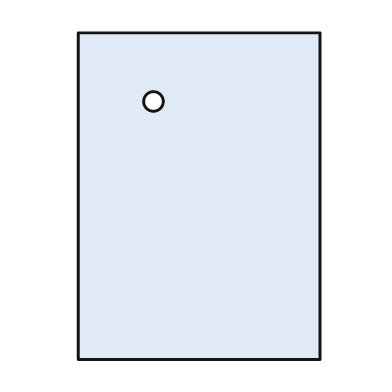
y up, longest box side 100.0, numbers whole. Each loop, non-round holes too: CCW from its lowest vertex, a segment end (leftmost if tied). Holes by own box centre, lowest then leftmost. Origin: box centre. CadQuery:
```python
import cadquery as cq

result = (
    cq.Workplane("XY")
    .moveTo(-37.0, -50.0)
    .lineTo(37.0, -50.0)
    .lineTo(37.0, 50.0)
    .lineTo(-37.0, 50.0)
    .close()
    .moveTo(-14.0, 29.0)
    .circle(3.0)
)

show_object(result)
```